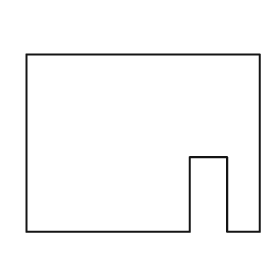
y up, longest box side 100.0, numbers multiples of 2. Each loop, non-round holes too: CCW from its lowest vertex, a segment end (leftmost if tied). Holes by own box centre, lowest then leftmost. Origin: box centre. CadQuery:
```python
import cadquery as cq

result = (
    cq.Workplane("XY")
    .moveTo(-50.0, -38.0)
    .lineTo(20.0, -38.0)
    .lineTo(20.0, -6.0)
    .lineTo(36.0, -6.0)
    .lineTo(36.0, -38.0)
    .lineTo(50.0, -38.0)
    .lineTo(50.0, 38.0)
    .lineTo(-50.0, 38.0)
    .close()
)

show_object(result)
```